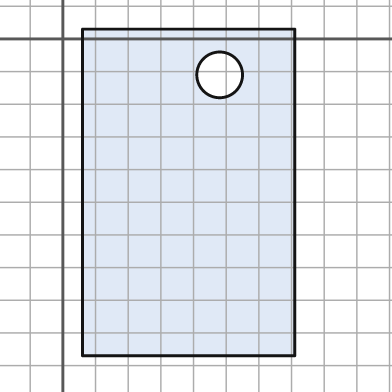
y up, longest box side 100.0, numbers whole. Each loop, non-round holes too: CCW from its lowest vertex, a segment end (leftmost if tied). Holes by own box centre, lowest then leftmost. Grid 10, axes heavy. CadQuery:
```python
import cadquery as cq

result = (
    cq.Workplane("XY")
    .moveTo(6.0, -97.0)
    .lineTo(71.0, -97.0)
    .lineTo(71.0, 3.0)
    .lineTo(6.0, 3.0)
    .close()
    .moveTo(48.0, -11.0)
    .circle(7.0)
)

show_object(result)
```